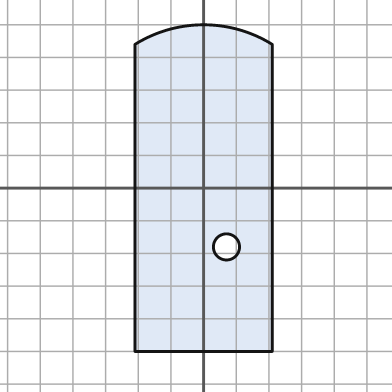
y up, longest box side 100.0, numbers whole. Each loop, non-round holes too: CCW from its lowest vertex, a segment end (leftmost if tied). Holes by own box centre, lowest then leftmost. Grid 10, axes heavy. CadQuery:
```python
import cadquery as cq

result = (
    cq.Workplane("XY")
    .moveTo(-21.0, -50.0)
    .lineTo(21.0, -50.0)
    .lineTo(21.0, 44.0)
    .threePointArc((0.0, 50.0), (-21.0, 44.0))
    .close()
    .moveTo(7.0, -18.0)
    .circle(4.0)
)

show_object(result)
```